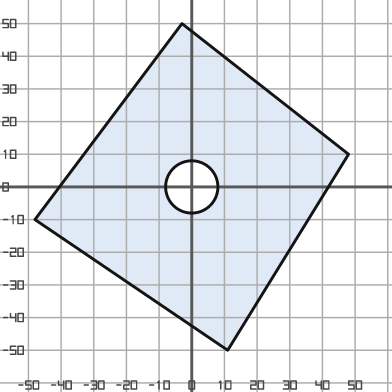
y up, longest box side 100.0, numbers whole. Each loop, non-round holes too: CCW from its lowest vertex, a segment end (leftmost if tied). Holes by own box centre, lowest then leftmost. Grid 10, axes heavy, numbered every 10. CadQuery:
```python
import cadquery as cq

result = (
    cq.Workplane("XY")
    .moveTo(11.0, -50.0)
    .lineTo(48.0, 10.0)
    .lineTo(-3.0, 50.0)
    .lineTo(-48.0, -10.0)
    .close()
    .moveTo(0.0, 0.0)
    .circle(8.0)
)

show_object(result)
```